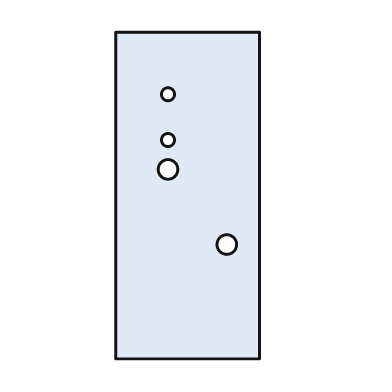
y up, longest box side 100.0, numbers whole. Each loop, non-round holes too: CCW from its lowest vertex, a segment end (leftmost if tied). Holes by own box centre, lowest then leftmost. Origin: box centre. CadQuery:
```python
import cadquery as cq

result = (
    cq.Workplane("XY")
    .moveTo(-22.0, -50.0)
    .lineTo(22.0, -50.0)
    .lineTo(22.0, 50.0)
    .lineTo(-22.0, 50.0)
    .close()
    .moveTo(12.0, -15.0)
    .circle(3.0)
    .moveTo(-6.0, 8.0)
    .circle(3.0)
    .moveTo(-6.0, 17.0)
    .circle(2.0)
    .moveTo(-6.0, 31.0)
    .circle(2.0)
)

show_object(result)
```